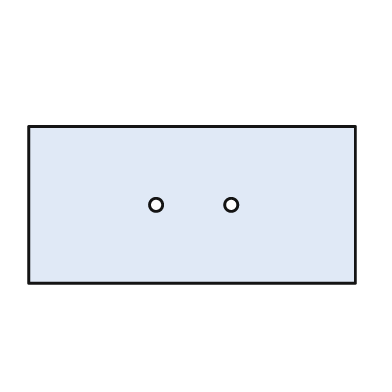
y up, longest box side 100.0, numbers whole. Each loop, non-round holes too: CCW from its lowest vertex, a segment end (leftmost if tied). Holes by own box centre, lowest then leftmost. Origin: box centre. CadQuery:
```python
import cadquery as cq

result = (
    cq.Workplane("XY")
    .moveTo(-50.0, -24.0)
    .lineTo(50.0, -24.0)
    .lineTo(50.0, 24.0)
    .lineTo(-50.0, 24.0)
    .close()
    .moveTo(-11.0, 0.0)
    .circle(2.0)
    .moveTo(12.0, 0.0)
    .circle(2.0)
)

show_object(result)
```